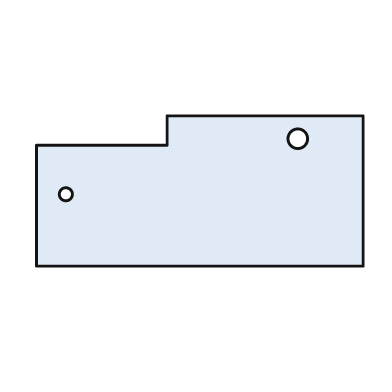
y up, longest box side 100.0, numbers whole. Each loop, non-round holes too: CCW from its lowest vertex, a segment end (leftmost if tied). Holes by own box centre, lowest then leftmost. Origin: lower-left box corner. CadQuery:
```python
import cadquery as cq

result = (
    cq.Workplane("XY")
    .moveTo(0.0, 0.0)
    .lineTo(100.0, 0.0)
    .lineTo(100.0, 46.0)
    .lineTo(40.0, 46.0)
    .lineTo(40.0, 37.0)
    .lineTo(0.0, 37.0)
    .close()
    .moveTo(9.0, 22.0)
    .circle(2.0)
    .moveTo(80.0, 39.0)
    .circle(3.0)
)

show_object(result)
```